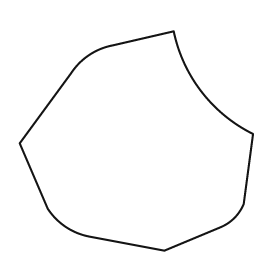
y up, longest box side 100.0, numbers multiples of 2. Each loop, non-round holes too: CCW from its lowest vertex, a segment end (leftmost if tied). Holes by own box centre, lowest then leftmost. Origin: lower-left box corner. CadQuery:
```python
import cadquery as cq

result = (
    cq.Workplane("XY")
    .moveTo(62.0, 0.0)
    .lineTo(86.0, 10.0)
    .threePointArc((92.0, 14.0), (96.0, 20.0))
    .lineTo(100.0, 50.0)
    .threePointArc((78.0, 68.0), (66.0, 94.0))
    .lineTo(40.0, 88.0)
    .threePointArc((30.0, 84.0), (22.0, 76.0))
    .lineTo(0.0, 46.0)
    .lineTo(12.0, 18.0)
    .threePointArc((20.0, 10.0), (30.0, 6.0))
    .close()
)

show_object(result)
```